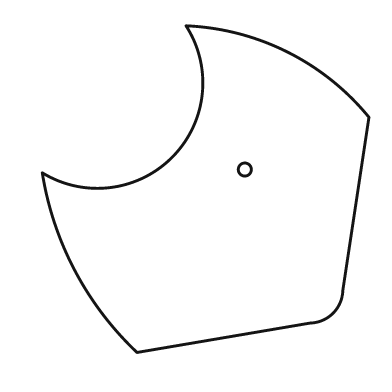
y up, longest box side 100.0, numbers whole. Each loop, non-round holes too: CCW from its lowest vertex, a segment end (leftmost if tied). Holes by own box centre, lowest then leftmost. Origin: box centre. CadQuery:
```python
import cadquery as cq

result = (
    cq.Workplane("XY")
    .moveTo(-21.0, -50.0)
    .lineTo(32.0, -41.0)
    .threePointArc((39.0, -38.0), (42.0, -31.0))
    .lineTo(50.0, 22.0)
    .threePointArc((25.0, 42.0), (-6.0, 50.0))
    .threePointArc((-10.0, 10.0), (-50.0, 5.0))
    .threePointArc((-40.0, -25.0), (-21.0, -50.0))
    .close()
    .moveTo(12.0, 6.0)
    .circle(2.0)
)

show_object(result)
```